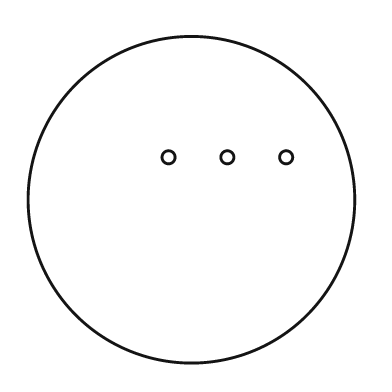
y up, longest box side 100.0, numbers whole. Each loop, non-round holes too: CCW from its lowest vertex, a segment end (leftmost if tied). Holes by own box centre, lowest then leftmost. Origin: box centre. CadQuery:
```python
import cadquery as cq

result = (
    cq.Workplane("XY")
    .moveTo(0.0, 0.0)
    .circle(50.0)
    .moveTo(-7.0, 13.0)
    .circle(2.0)
    .moveTo(11.0, 13.0)
    .circle(2.0)
    .moveTo(29.0, 13.0)
    .circle(2.0)
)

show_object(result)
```